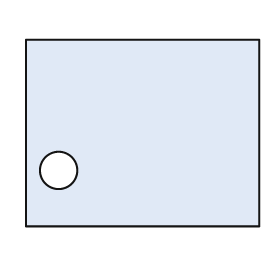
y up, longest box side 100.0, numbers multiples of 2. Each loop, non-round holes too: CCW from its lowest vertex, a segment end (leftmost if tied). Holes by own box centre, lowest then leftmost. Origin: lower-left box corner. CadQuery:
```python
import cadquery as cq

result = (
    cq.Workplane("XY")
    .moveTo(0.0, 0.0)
    .lineTo(100.0, 0.0)
    .lineTo(100.0, 80.0)
    .lineTo(0.0, 80.0)
    .close()
    .moveTo(14.0, 24.0)
    .circle(8.0)
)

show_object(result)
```